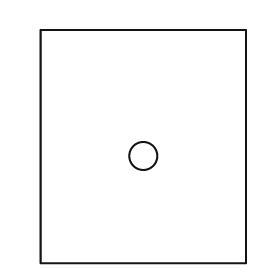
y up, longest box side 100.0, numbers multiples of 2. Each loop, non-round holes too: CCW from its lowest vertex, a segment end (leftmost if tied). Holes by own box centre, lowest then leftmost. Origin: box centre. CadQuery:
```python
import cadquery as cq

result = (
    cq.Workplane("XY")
    .moveTo(-44.0, -50.0)
    .lineTo(44.0, -50.0)
    .lineTo(44.0, 50.0)
    .lineTo(-44.0, 50.0)
    .close()
    .moveTo(0.0, -4.0)
    .circle(6.0)
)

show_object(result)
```